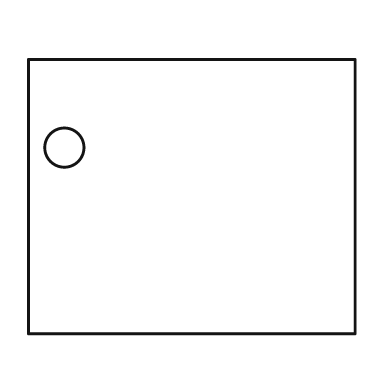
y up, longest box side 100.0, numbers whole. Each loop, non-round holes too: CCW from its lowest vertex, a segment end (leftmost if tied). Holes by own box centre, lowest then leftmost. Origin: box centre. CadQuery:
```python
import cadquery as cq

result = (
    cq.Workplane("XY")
    .moveTo(-50.0, -42.0)
    .lineTo(50.0, -42.0)
    .lineTo(50.0, 42.0)
    .lineTo(-50.0, 42.0)
    .close()
    .moveTo(-39.0, 15.0)
    .circle(6.0)
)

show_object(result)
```